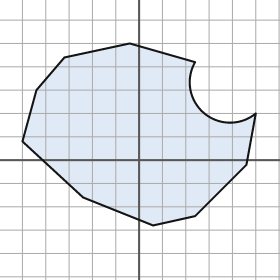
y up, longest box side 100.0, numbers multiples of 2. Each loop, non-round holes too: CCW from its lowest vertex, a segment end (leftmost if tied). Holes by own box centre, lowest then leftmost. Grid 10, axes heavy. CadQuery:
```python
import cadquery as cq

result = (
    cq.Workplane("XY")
    .moveTo(6.0, -28.0)
    .lineTo(24.0, -24.0)
    .lineTo(46.0, -2.0)
    .lineTo(50.0, 20.0)
    .threePointArc((28.0, 20.0), (24.0, 42.0))
    .lineTo(-4.0, 50.0)
    .lineTo(-32.0, 44.0)
    .lineTo(-44.0, 30.0)
    .lineTo(-50.0, 8.0)
    .lineTo(-24.0, -16.0)
    .close()
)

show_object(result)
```